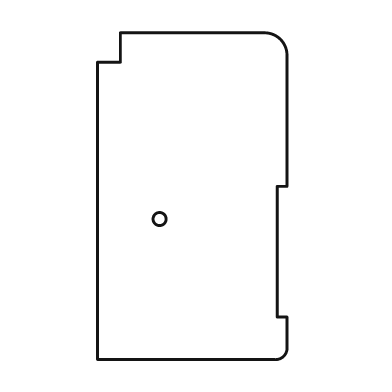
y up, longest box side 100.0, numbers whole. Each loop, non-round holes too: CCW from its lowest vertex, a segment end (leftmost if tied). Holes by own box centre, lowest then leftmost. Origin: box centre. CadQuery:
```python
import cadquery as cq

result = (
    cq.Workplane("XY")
    .moveTo(-29.0, -50.0)
    .lineTo(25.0, -50.0)
    .threePointArc((28.0, -49.0), (29.0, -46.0))
    .lineTo(29.0, -37.0)
    .lineTo(26.0, -37.0)
    .lineTo(26.0, 3.0)
    .lineTo(29.0, 3.0)
    .lineTo(29.0, 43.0)
    .threePointArc((27.0, 48.0), (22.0, 50.0))
    .lineTo(-22.0, 50.0)
    .lineTo(-22.0, 41.0)
    .lineTo(-29.0, 41.0)
    .close()
    .moveTo(-10.0, -7.0)
    .circle(2.0)
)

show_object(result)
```